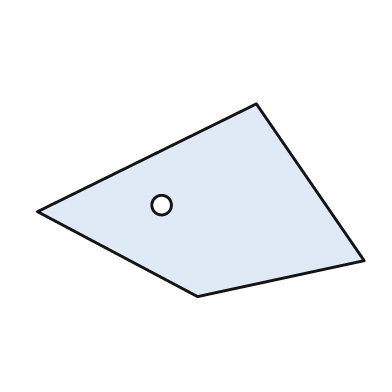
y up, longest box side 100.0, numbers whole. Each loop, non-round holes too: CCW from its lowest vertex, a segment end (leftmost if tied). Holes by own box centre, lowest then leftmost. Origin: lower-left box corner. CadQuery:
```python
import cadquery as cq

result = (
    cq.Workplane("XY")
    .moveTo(49.0, 0.0)
    .lineTo(100.0, 11.0)
    .lineTo(67.0, 59.0)
    .lineTo(0.0, 26.0)
    .close()
    .moveTo(38.0, 28.0)
    .circle(3.0)
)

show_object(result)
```